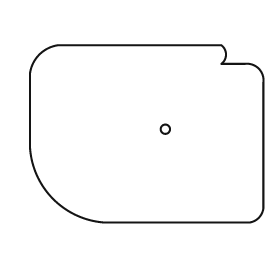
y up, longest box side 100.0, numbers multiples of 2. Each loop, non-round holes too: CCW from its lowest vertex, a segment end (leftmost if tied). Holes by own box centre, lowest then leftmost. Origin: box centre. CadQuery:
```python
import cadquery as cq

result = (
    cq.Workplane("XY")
    .moveTo(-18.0, -38.0)
    .lineTo(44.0, -38.0)
    .threePointArc((48.0, -36.0), (50.0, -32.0))
    .lineTo(50.0, 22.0)
    .threePointArc((48.0, 28.0), (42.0, 30.0))
    .lineTo(32.0, 30.0)
    .threePointArc((34.0, 34.0), (32.0, 38.0))
    .lineTo(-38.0, 38.0)
    .threePointArc((-46.0, 34.0), (-50.0, 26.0))
    .lineTo(-50.0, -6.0)
    .threePointArc((-40.0, -28.0), (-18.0, -38.0))
    .close()
    .moveTo(8.0, 2.0)
    .circle(2.0)
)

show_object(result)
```